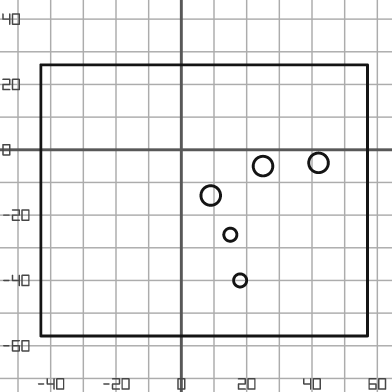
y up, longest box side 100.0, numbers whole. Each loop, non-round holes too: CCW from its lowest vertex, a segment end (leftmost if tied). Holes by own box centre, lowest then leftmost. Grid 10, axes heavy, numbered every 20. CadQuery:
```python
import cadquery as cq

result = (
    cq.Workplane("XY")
    .moveTo(-43.0, -57.0)
    .lineTo(57.0, -57.0)
    .lineTo(57.0, 26.0)
    .lineTo(-43.0, 26.0)
    .close()
    .moveTo(18.0, -40.0)
    .circle(2.0)
    .moveTo(15.0, -26.0)
    .circle(2.0)
    .moveTo(9.0, -14.0)
    .circle(3.0)
    .moveTo(25.0, -5.0)
    .circle(3.0)
    .moveTo(42.0, -4.0)
    .circle(3.0)
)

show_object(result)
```